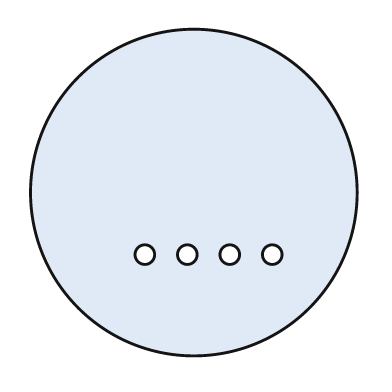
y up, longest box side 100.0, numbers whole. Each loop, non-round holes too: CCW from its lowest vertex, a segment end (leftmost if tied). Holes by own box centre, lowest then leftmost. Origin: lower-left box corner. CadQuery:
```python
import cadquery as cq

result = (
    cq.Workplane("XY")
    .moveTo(50.0, 50.0)
    .circle(50.0)
    .moveTo(35.0, 31.0)
    .circle(3.0)
    .moveTo(48.0, 31.0)
    .circle(3.0)
    .moveTo(61.0, 31.0)
    .circle(3.0)
    .moveTo(74.0, 31.0)
    .circle(3.0)
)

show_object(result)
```